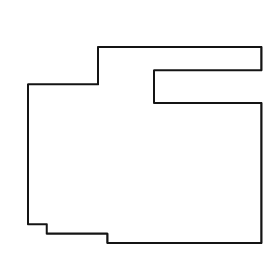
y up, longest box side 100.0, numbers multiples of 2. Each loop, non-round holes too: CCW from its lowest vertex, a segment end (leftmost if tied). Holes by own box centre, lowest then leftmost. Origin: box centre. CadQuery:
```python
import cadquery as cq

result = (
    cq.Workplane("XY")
    .moveTo(-16.0, -42.0)
    .lineTo(50.0, -42.0)
    .lineTo(50.0, 18.0)
    .lineTo(4.0, 18.0)
    .lineTo(4.0, 32.0)
    .lineTo(50.0, 32.0)
    .lineTo(50.0, 42.0)
    .lineTo(-20.0, 42.0)
    .lineTo(-20.0, 26.0)
    .lineTo(-50.0, 26.0)
    .lineTo(-50.0, -34.0)
    .lineTo(-42.0, -34.0)
    .lineTo(-42.0, -38.0)
    .lineTo(-16.0, -38.0)
    .close()
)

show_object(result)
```